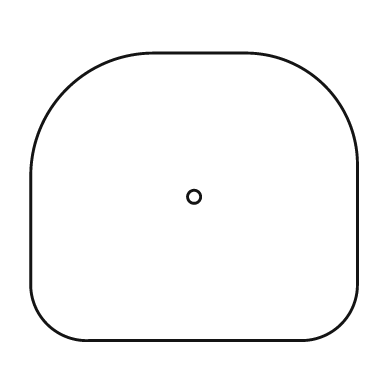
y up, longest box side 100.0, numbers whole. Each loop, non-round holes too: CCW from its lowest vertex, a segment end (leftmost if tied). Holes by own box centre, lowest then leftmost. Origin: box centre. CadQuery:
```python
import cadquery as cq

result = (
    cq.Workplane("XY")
    .moveTo(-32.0, -44.0)
    .lineTo(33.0, -44.0)
    .threePointArc((45.0, -39.0), (50.0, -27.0))
    .lineTo(50.0, 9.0)
    .threePointArc((40.0, 34.0), (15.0, 44.0))
    .lineTo(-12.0, 44.0)
    .threePointArc((-39.0, 33.0), (-50.0, 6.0))
    .lineTo(-50.0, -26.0)
    .threePointArc((-45.0, -39.0), (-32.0, -44.0))
    .close()
    .moveTo(0.0, 0.0)
    .circle(2.0)
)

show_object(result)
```